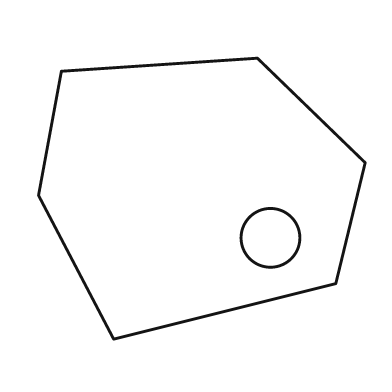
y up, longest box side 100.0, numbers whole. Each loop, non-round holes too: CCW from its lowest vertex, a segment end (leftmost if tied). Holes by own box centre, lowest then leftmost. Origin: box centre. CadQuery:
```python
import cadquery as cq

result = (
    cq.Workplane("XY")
    .moveTo(-27.0, -43.0)
    .lineTo(41.0, -26.0)
    .lineTo(50.0, 11.0)
    .lineTo(17.0, 43.0)
    .lineTo(-43.0, 39.0)
    .lineTo(-50.0, 1.0)
    .close()
    .moveTo(21.0, -12.0)
    .circle(9.0)
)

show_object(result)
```